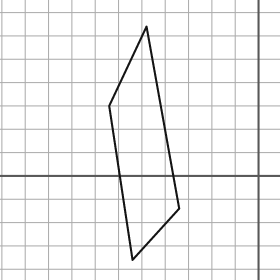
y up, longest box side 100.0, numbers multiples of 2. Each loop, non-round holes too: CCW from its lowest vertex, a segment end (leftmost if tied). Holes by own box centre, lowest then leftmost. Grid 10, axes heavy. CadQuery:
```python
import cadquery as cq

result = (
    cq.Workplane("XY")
    .moveTo(-54.0, -36.0)
    .lineTo(-34.0, -14.0)
    .lineTo(-48.0, 64.0)
    .lineTo(-64.0, 30.0)
    .close()
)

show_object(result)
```